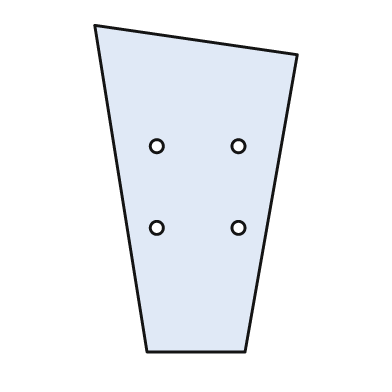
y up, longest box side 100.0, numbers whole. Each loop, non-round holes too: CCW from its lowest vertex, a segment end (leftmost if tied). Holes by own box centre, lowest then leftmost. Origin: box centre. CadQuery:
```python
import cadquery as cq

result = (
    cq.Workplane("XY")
    .moveTo(-15.0, -50.0)
    .lineTo(15.0, -50.0)
    .lineTo(31.0, 41.0)
    .lineTo(-31.0, 50.0)
    .close()
    .moveTo(-12.0, -12.0)
    .circle(2.0)
    .moveTo(13.0, -12.0)
    .circle(2.0)
    .moveTo(-12.0, 13.0)
    .circle(2.0)
    .moveTo(13.0, 13.0)
    .circle(2.0)
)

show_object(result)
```